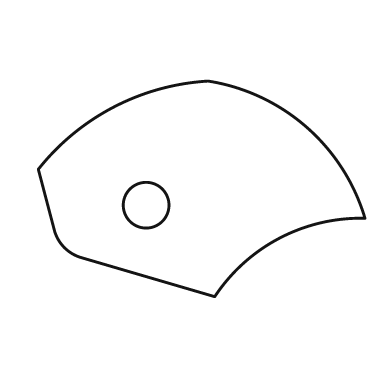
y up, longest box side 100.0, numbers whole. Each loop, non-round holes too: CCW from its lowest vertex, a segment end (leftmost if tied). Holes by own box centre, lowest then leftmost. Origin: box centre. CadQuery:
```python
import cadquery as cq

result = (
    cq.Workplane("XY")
    .moveTo(4.0, -33.0)
    .threePointArc((24.0, -15.0), (50.0, -9.0))
    .threePointArc((32.0, 19.0), (2.0, 33.0))
    .threePointArc((-27.0, 25.0), (-50.0, 6.0))
    .lineTo(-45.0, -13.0)
    .threePointArc((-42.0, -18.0), (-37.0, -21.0))
    .close()
    .moveTo(-17.0, -5.0)
    .circle(7.0)
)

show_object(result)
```